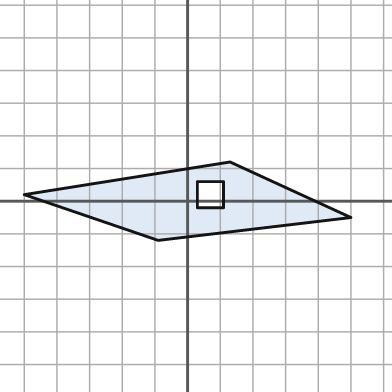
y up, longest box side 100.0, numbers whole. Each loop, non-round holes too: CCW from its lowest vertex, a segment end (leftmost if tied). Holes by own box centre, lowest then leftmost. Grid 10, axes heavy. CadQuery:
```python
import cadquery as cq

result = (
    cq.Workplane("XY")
    .moveTo(-9.0, -12.0)
    .lineTo(50.0, -5.0)
    .lineTo(13.0, 12.0)
    .lineTo(-50.0, 2.0)
    .close()
    .moveTo(3.0, -2.0)
    .lineTo(11.0, -2.0)
    .lineTo(11.0, 6.0)
    .lineTo(3.0, 6.0)
    .close()
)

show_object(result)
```